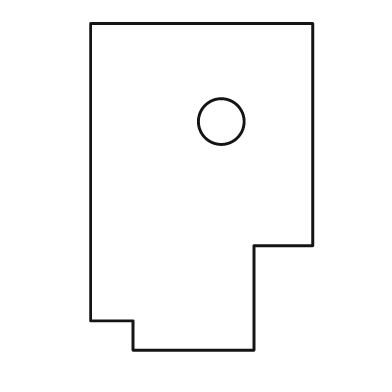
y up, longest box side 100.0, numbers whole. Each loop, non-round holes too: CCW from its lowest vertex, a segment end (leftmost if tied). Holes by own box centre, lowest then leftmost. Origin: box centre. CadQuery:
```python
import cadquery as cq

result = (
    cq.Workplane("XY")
    .moveTo(-21.0, -50.0)
    .lineTo(16.0, -50.0)
    .lineTo(16.0, -18.0)
    .lineTo(34.0, -18.0)
    .lineTo(34.0, 50.0)
    .lineTo(-34.0, 50.0)
    .lineTo(-34.0, -41.0)
    .lineTo(-21.0, -41.0)
    .close()
    .moveTo(6.0, 20.0)
    .circle(7.0)
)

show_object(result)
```